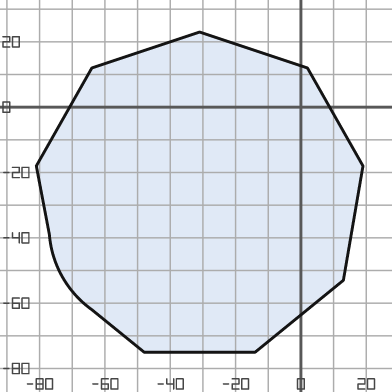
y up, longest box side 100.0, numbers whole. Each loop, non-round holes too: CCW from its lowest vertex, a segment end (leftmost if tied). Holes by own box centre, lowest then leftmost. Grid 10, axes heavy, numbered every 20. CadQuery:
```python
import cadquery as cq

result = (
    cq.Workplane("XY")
    .moveTo(-48.0, -75.0)
    .lineTo(-14.0, -75.0)
    .lineTo(13.0, -53.0)
    .lineTo(19.0, -18.0)
    .lineTo(2.0, 12.0)
    .lineTo(-31.0, 23.0)
    .lineTo(-64.0, 12.0)
    .lineTo(-81.0, -18.0)
    .lineTo(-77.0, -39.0)
    .threePointArc((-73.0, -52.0), (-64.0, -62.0))
    .close()
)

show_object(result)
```